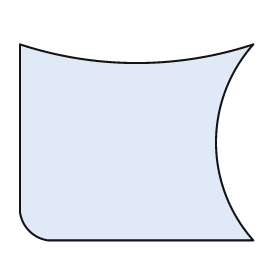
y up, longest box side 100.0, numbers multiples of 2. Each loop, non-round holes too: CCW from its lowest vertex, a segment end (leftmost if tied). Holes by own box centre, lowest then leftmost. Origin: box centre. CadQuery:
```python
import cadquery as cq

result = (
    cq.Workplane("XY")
    .moveTo(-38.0, -42.0)
    .lineTo(50.0, -42.0)
    .threePointArc((34.0, 0.0), (50.0, 42.0))
    .threePointArc((0.0, 34.0), (-50.0, 42.0))
    .lineTo(-50.0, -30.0)
    .threePointArc((-46.0, -38.0), (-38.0, -42.0))
    .close()
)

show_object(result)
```